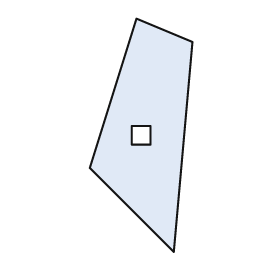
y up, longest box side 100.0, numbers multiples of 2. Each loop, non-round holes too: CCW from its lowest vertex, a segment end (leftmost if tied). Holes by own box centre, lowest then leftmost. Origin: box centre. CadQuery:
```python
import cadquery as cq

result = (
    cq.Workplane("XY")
    .moveTo(14.0, -50.0)
    .lineTo(22.0, 40.0)
    .lineTo(-2.0, 50.0)
    .lineTo(-22.0, -14.0)
    .close()
    .moveTo(-4.0, -4.0)
    .lineTo(4.0, -4.0)
    .lineTo(4.0, 4.0)
    .lineTo(-4.0, 4.0)
    .close()
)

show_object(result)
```